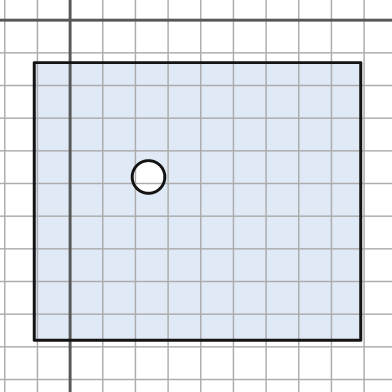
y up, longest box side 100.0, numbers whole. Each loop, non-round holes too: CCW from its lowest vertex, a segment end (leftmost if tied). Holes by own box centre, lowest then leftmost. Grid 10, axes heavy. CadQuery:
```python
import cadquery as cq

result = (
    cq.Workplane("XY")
    .moveTo(-11.0, -98.0)
    .lineTo(89.0, -98.0)
    .lineTo(89.0, -13.0)
    .lineTo(-11.0, -13.0)
    .close()
    .moveTo(24.0, -48.0)
    .circle(5.0)
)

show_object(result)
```